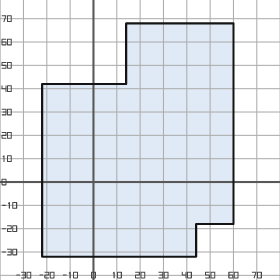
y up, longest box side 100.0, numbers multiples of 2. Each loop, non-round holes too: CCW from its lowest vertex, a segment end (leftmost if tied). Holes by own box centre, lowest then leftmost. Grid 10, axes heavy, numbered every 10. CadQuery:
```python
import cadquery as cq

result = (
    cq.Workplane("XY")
    .moveTo(-22.0, -32.0)
    .lineTo(44.0, -32.0)
    .lineTo(44.0, -18.0)
    .lineTo(60.0, -18.0)
    .lineTo(60.0, 68.0)
    .lineTo(14.0, 68.0)
    .lineTo(14.0, 42.0)
    .lineTo(-22.0, 42.0)
    .close()
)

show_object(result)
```